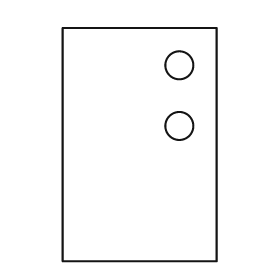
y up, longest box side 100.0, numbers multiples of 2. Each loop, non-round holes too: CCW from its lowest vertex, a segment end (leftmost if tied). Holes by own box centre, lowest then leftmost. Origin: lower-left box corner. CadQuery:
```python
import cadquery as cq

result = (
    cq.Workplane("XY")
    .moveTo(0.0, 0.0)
    .lineTo(66.0, 0.0)
    .lineTo(66.0, 100.0)
    .lineTo(0.0, 100.0)
    .close()
    .moveTo(50.0, 58.0)
    .circle(6.0)
    .moveTo(50.0, 84.0)
    .circle(6.0)
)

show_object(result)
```